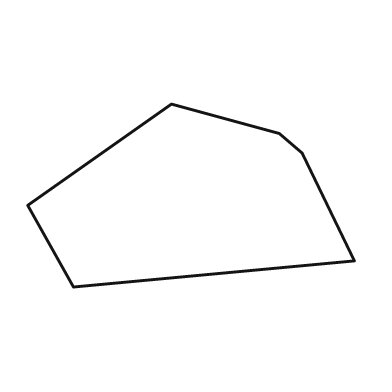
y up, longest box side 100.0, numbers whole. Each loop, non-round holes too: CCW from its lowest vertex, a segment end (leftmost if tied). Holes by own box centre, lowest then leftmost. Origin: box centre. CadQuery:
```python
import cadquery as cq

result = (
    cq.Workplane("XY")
    .moveTo(-36.0, -28.0)
    .lineTo(50.0, -20.0)
    .lineTo(34.0, 13.0)
    .lineTo(27.0, 19.0)
    .lineTo(-6.0, 28.0)
    .lineTo(-50.0, -3.0)
    .close()
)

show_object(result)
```